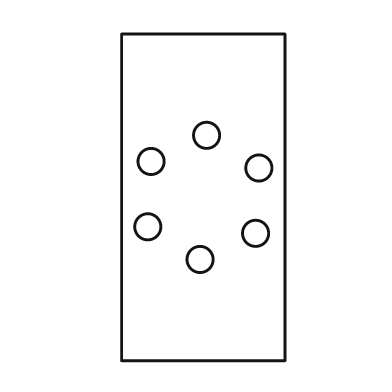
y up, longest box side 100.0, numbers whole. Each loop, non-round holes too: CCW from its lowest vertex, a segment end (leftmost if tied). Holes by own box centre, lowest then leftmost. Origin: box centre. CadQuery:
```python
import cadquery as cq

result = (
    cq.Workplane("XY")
    .moveTo(-25.0, -50.0)
    .lineTo(25.0, -50.0)
    .lineTo(25.0, 50.0)
    .lineTo(-25.0, 50.0)
    .close()
    .moveTo(-1.0, -19.0)
    .circle(4.0)
    .moveTo(16.0, -11.0)
    .circle(4.0)
    .moveTo(-17.0, -9.0)
    .circle(4.0)
    .moveTo(17.0, 9.0)
    .circle(4.0)
    .moveTo(-16.0, 11.0)
    .circle(4.0)
    .moveTo(1.0, 19.0)
    .circle(4.0)
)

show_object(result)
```